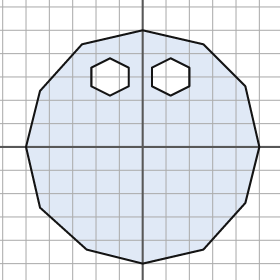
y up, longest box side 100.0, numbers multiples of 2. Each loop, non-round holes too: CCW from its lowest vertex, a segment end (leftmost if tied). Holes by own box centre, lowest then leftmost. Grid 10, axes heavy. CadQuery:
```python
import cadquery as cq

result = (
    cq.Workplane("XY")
    .moveTo(0.0, -50.0)
    .lineTo(26.0, -44.0)
    .lineTo(44.0, -24.0)
    .lineTo(50.0, 0.0)
    .lineTo(44.0, 26.0)
    .lineTo(26.0, 44.0)
    .lineTo(0.0, 50.0)
    .lineTo(-26.0, 44.0)
    .lineTo(-44.0, 24.0)
    .lineTo(-50.0, 0.0)
    .lineTo(-44.0, -26.0)
    .lineTo(-24.0, -44.0)
    .close()
    .moveTo(-14.0, 22.0)
    .lineTo(-6.0, 26.0)
    .lineTo(-6.0, 34.0)
    .lineTo(-14.0, 38.0)
    .lineTo(-22.0, 34.0)
    .lineTo(-22.0, 26.0)
    .close()
    .moveTo(12.0, 22.0)
    .lineTo(20.0, 26.0)
    .lineTo(20.0, 34.0)
    .lineTo(12.0, 38.0)
    .lineTo(4.0, 34.0)
    .lineTo(4.0, 26.0)
    .close()
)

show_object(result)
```